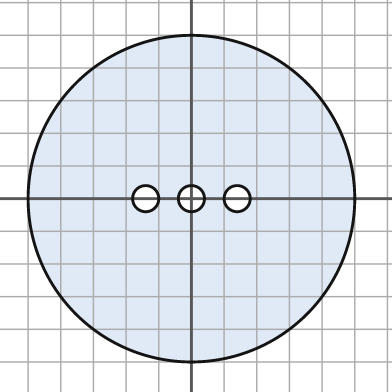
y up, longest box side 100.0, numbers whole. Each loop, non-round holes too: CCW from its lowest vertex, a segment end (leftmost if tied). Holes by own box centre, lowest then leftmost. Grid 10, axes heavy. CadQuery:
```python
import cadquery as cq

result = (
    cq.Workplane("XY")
    .moveTo(0.0, 0.0)
    .circle(50.0)
    .moveTo(-14.0, 0.0)
    .circle(4.0)
    .moveTo(0.0, 0.0)
    .circle(4.0)
    .moveTo(14.0, 0.0)
    .circle(4.0)
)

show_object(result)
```